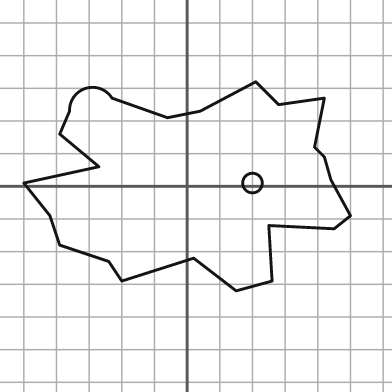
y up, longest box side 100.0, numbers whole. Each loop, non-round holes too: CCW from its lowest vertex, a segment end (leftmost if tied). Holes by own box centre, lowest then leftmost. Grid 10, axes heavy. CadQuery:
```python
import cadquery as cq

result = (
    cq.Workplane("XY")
    .moveTo(15.0, -32.0)
    .lineTo(26.0, -29.0)
    .lineTo(25.0, -12.0)
    .lineTo(45.0, -13.0)
    .lineTo(50.0, -9.0)
    .lineTo(44.0, 2.0)
    .lineTo(42.0, 9.0)
    .lineTo(39.0, 12.0)
    .lineTo(42.0, 27.0)
    .lineTo(28.0, 25.0)
    .lineTo(21.0, 32.0)
    .lineTo(4.0, 23.0)
    .lineTo(-6.0, 21.0)
    .lineTo(-23.0, 27.0)
    .threePointArc((-31.0, 30.0), (-36.0, 23.0))
    .lineTo(-39.0, 16.0)
    .lineTo(-27.0, 6.0)
    .lineTo(-50.0, 1.0)
    .lineTo(-42.0, -9.0)
    .lineTo(-39.0, -18.0)
    .lineTo(-24.0, -23.0)
    .lineTo(-20.0, -29.0)
    .lineTo(2.0, -22.0)
    .close()
    .moveTo(20.0, 1.0)
    .circle(3.0)
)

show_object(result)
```